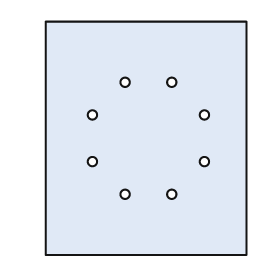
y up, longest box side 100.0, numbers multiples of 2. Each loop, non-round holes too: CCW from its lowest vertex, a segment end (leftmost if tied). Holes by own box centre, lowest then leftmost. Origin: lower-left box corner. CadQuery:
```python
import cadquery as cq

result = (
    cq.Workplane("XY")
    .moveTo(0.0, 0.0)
    .lineTo(86.0, 0.0)
    .lineTo(86.0, 100.0)
    .lineTo(0.0, 100.0)
    .close()
    .moveTo(34.0, 26.0)
    .circle(2.0)
    .moveTo(54.0, 26.0)
    .circle(2.0)
    .moveTo(20.0, 40.0)
    .circle(2.0)
    .moveTo(68.0, 40.0)
    .circle(2.0)
    .moveTo(20.0, 60.0)
    .circle(2.0)
    .moveTo(68.0, 60.0)
    .circle(2.0)
    .moveTo(34.0, 74.0)
    .circle(2.0)
    .moveTo(54.0, 74.0)
    .circle(2.0)
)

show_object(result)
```